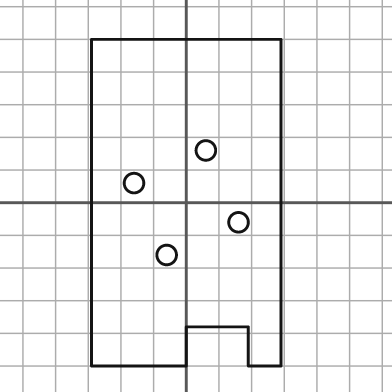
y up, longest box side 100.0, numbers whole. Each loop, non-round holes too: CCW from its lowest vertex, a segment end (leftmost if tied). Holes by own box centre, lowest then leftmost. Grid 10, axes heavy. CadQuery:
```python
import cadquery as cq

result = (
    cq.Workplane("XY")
    .moveTo(-29.0, -50.0)
    .lineTo(0.0, -50.0)
    .lineTo(0.0, -38.0)
    .lineTo(19.0, -38.0)
    .lineTo(19.0, -50.0)
    .lineTo(29.0, -50.0)
    .lineTo(29.0, 50.0)
    .lineTo(-29.0, 50.0)
    .close()
    .moveTo(-6.0, -16.0)
    .circle(3.0)
    .moveTo(16.0, -6.0)
    .circle(3.0)
    .moveTo(-16.0, 6.0)
    .circle(3.0)
    .moveTo(6.0, 16.0)
    .circle(3.0)
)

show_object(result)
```